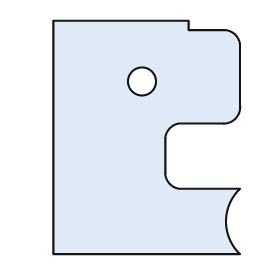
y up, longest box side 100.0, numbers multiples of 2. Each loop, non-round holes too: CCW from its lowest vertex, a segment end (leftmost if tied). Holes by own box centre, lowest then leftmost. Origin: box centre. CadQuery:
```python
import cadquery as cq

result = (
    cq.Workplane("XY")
    .moveTo(-40.0, -50.0)
    .lineTo(40.0, -50.0)
    .threePointArc((34.0, -36.0), (40.0, -22.0))
    .lineTo(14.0, -22.0)
    .threePointArc((10.0, -20.0), (8.0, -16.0))
    .lineTo(8.0, 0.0)
    .threePointArc((10.0, 4.0), (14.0, 6.0))
    .lineTo(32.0, 6.0)
    .threePointArc((38.0, 8.0), (40.0, 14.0))
    .lineTo(40.0, 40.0)
    .threePointArc((38.0, 44.0), (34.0, 46.0))
    .lineTo(18.0, 46.0)
    .lineTo(18.0, 50.0)
    .lineTo(-40.0, 50.0)
    .close()
    .moveTo(-2.0, 24.0)
    .circle(6.0)
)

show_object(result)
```